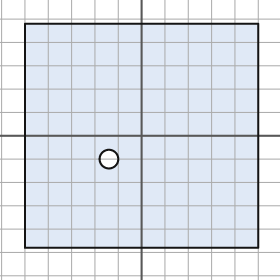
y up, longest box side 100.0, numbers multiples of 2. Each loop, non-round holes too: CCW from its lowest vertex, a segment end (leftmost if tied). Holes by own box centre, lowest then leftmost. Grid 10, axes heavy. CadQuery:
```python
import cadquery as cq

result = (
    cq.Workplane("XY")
    .moveTo(-50.0, -48.0)
    .lineTo(50.0, -48.0)
    .lineTo(50.0, 48.0)
    .lineTo(-50.0, 48.0)
    .close()
    .moveTo(-14.0, -10.0)
    .circle(4.0)
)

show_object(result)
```